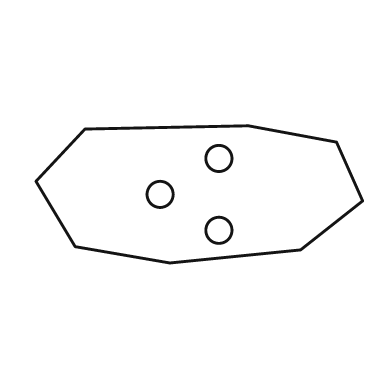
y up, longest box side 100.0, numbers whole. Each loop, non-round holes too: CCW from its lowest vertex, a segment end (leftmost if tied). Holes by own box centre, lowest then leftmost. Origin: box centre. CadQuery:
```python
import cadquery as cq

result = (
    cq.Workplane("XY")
    .moveTo(-9.0, -21.0)
    .lineTo(31.0, -17.0)
    .lineTo(50.0, -2.0)
    .lineTo(42.0, 16.0)
    .lineTo(15.0, 21.0)
    .lineTo(-35.0, 20.0)
    .lineTo(-50.0, 4.0)
    .lineTo(-38.0, -16.0)
    .close()
    .moveTo(6.0, -11.0)
    .circle(4.0)
    .moveTo(-12.0, 0.0)
    .circle(4.0)
    .moveTo(6.0, 11.0)
    .circle(4.0)
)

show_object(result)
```